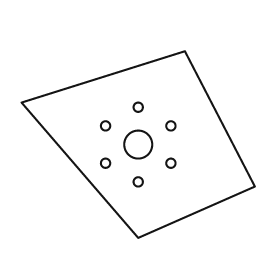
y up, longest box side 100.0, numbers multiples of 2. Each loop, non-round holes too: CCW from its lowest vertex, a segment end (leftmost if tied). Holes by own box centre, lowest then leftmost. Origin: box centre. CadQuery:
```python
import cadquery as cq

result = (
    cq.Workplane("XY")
    .moveTo(0.0, -40.0)
    .lineTo(50.0, -18.0)
    .lineTo(20.0, 40.0)
    .lineTo(-50.0, 18.0)
    .close()
    .moveTo(0.0, -16.0)
    .circle(2.0)
    .moveTo(-14.0, -8.0)
    .circle(2.0)
    .moveTo(14.0, -8.0)
    .circle(2.0)
    .moveTo(0.0, 0.0)
    .circle(6.0)
    .moveTo(-14.0, 8.0)
    .circle(2.0)
    .moveTo(14.0, 8.0)
    .circle(2.0)
    .moveTo(0.0, 16.0)
    .circle(2.0)
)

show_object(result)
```